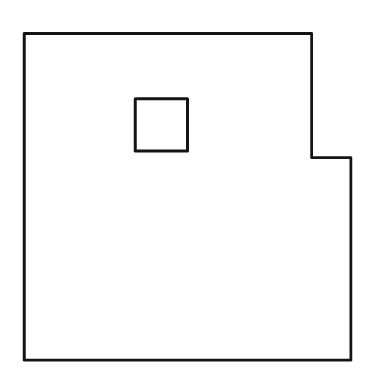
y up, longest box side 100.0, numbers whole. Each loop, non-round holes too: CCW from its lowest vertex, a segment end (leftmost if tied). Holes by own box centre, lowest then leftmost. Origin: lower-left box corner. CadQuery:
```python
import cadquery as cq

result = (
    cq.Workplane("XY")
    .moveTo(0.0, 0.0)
    .lineTo(100.0, 0.0)
    .lineTo(100.0, 62.0)
    .lineTo(88.0, 62.0)
    .lineTo(88.0, 100.0)
    .lineTo(0.0, 100.0)
    .close()
    .moveTo(34.0, 64.0)
    .lineTo(50.0, 64.0)
    .lineTo(50.0, 80.0)
    .lineTo(34.0, 80.0)
    .close()
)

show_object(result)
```